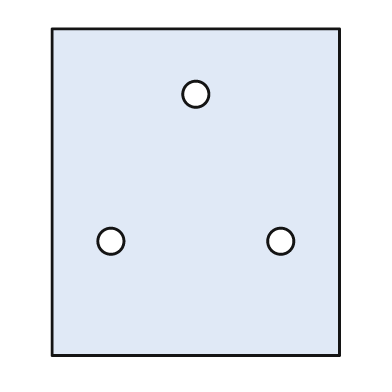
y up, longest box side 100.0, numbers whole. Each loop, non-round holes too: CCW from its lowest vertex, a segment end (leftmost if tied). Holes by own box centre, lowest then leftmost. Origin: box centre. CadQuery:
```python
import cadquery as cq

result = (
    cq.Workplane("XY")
    .moveTo(-44.0, -50.0)
    .lineTo(44.0, -50.0)
    .lineTo(44.0, 50.0)
    .lineTo(-44.0, 50.0)
    .close()
    .moveTo(-26.0, -15.0)
    .circle(4.0)
    .moveTo(26.0, -15.0)
    .circle(4.0)
    .moveTo(0.0, 30.0)
    .circle(4.0)
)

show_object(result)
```